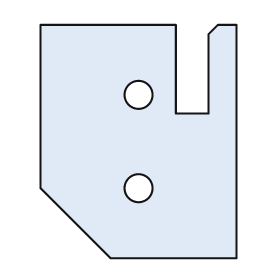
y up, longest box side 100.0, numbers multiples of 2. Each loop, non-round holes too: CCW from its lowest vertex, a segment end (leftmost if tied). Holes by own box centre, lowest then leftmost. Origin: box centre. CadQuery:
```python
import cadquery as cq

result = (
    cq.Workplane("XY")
    .moveTo(-12.0, -50.0)
    .lineTo(42.0, -50.0)
    .lineTo(42.0, 50.0)
    .lineTo(34.0, 50.0)
    .lineTo(30.0, 46.0)
    .lineTo(30.0, 12.0)
    .lineTo(16.0, 12.0)
    .lineTo(16.0, 50.0)
    .lineTo(-42.0, 50.0)
    .lineTo(-42.0, -20.0)
    .close()
    .moveTo(0.0, -20.0)
    .circle(6.0)
    .moveTo(0.0, 20.0)
    .circle(6.0)
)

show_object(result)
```